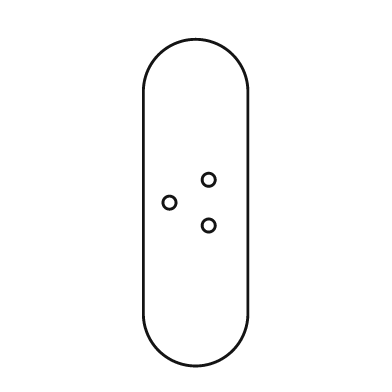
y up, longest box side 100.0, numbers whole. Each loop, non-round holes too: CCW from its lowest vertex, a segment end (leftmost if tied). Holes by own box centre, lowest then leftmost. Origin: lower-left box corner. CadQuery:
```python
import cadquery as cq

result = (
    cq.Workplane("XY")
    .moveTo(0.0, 16.0)
    .threePointArc((16.0, 0.0), (32.0, 16.0))
    .lineTo(32.0, 84.0)
    .threePointArc((16.0, 100.0), (0.0, 84.0))
    .close()
    .moveTo(20.0, 43.0)
    .circle(2.0)
    .moveTo(8.0, 50.0)
    .circle(2.0)
    .moveTo(20.0, 57.0)
    .circle(2.0)
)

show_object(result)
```